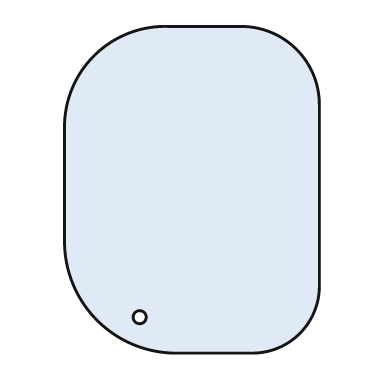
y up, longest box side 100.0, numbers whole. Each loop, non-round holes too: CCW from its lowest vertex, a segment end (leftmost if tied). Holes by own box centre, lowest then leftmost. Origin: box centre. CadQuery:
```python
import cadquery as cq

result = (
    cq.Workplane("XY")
    .moveTo(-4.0, -50.0)
    .lineTo(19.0, -50.0)
    .threePointArc((33.0, -44.0), (39.0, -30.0))
    .lineTo(39.0, 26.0)
    .threePointArc((32.0, 43.0), (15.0, 50.0))
    .lineTo(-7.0, 50.0)
    .threePointArc((-30.0, 41.0), (-39.0, 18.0))
    .lineTo(-39.0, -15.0)
    .threePointArc((-29.0, -40.0), (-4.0, -50.0))
    .close()
    .moveTo(-16.0, -39.0)
    .circle(2.0)
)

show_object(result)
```